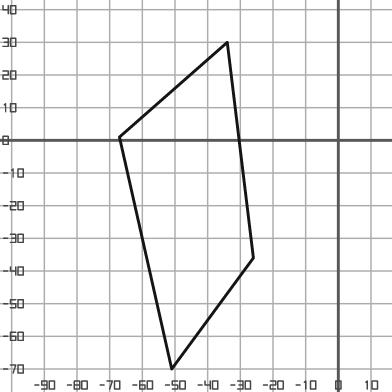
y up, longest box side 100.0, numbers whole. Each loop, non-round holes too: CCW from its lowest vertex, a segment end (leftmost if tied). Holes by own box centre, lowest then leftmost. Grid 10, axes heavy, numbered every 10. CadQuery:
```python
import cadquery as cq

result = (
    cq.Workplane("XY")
    .moveTo(-51.0, -70.0)
    .lineTo(-26.0, -36.0)
    .lineTo(-34.0, 30.0)
    .lineTo(-67.0, 1.0)
    .close()
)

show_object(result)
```